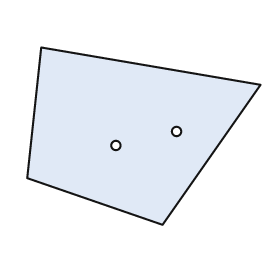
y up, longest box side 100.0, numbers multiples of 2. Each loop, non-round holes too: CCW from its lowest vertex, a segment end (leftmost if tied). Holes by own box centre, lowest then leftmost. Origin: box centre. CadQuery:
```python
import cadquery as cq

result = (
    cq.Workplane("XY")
    .moveTo(8.0, -38.0)
    .lineTo(50.0, 22.0)
    .lineTo(-44.0, 38.0)
    .lineTo(-50.0, -18.0)
    .close()
    .moveTo(-12.0, -4.0)
    .circle(2.0)
    .moveTo(14.0, 2.0)
    .circle(2.0)
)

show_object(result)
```